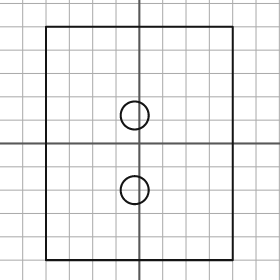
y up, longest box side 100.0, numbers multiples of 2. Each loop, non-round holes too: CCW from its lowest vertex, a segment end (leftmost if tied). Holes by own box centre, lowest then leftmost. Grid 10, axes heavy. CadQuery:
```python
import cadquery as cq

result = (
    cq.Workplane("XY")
    .moveTo(-40.0, -50.0)
    .lineTo(40.0, -50.0)
    .lineTo(40.0, 50.0)
    .lineTo(-40.0, 50.0)
    .close()
    .moveTo(-2.0, -20.0)
    .circle(6.0)
    .moveTo(-2.0, 12.0)
    .circle(6.0)
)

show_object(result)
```